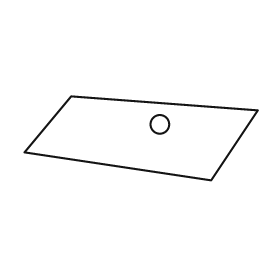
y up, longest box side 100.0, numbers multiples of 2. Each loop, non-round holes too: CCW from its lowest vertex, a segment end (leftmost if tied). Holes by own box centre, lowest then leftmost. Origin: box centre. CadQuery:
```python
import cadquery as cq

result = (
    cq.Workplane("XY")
    .moveTo(30.0, -18.0)
    .lineTo(50.0, 12.0)
    .lineTo(-30.0, 18.0)
    .lineTo(-50.0, -6.0)
    .close()
    .moveTo(8.0, 6.0)
    .circle(4.0)
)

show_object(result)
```